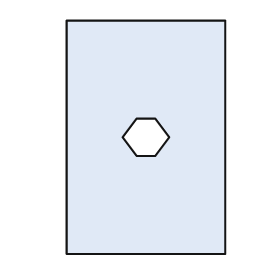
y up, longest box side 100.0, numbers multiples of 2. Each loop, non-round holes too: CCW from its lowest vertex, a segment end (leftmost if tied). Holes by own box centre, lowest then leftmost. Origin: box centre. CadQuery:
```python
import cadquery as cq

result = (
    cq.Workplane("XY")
    .moveTo(-34.0, -50.0)
    .lineTo(34.0, -50.0)
    .lineTo(34.0, 50.0)
    .lineTo(-34.0, 50.0)
    .close()
    .moveTo(-4.0, -8.0)
    .lineTo(4.0, -8.0)
    .lineTo(10.0, 0.0)
    .lineTo(4.0, 8.0)
    .lineTo(-4.0, 8.0)
    .lineTo(-10.0, 0.0)
    .close()
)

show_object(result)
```